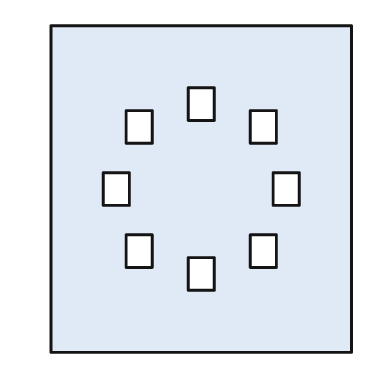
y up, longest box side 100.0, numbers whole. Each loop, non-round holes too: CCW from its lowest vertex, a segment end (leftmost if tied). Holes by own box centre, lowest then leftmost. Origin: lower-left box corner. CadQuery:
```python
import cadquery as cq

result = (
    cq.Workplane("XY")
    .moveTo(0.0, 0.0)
    .lineTo(92.0, 0.0)
    .lineTo(92.0, 100.0)
    .lineTo(0.0, 100.0)
    .close()
    .moveTo(42.0, 19.0)
    .lineTo(50.0, 19.0)
    .lineTo(50.0, 29.0)
    .lineTo(42.0, 29.0)
    .close()
    .moveTo(23.0, 26.0)
    .lineTo(31.0, 26.0)
    .lineTo(31.0, 36.0)
    .lineTo(23.0, 36.0)
    .close()
    .moveTo(61.0, 26.0)
    .lineTo(69.0, 26.0)
    .lineTo(69.0, 36.0)
    .lineTo(61.0, 36.0)
    .close()
    .moveTo(16.0, 45.0)
    .lineTo(24.0, 45.0)
    .lineTo(24.0, 55.0)
    .lineTo(16.0, 55.0)
    .close()
    .moveTo(68.0, 45.0)
    .lineTo(76.0, 45.0)
    .lineTo(76.0, 55.0)
    .lineTo(68.0, 55.0)
    .close()
    .moveTo(23.0, 64.0)
    .lineTo(31.0, 64.0)
    .lineTo(31.0, 74.0)
    .lineTo(23.0, 74.0)
    .close()
    .moveTo(61.0, 64.0)
    .lineTo(69.0, 64.0)
    .lineTo(69.0, 74.0)
    .lineTo(61.0, 74.0)
    .close()
    .moveTo(42.0, 71.0)
    .lineTo(50.0, 71.0)
    .lineTo(50.0, 81.0)
    .lineTo(42.0, 81.0)
    .close()
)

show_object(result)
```